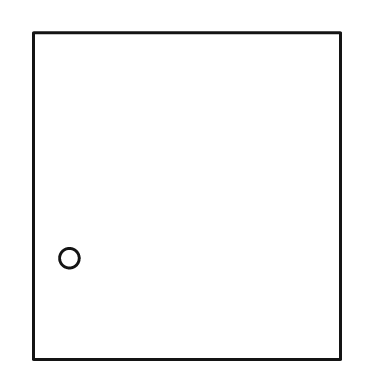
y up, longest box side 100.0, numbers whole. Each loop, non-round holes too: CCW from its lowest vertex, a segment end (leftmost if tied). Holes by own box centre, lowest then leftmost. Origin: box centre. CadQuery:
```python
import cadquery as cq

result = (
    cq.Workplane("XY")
    .moveTo(-47.0, -50.0)
    .lineTo(47.0, -50.0)
    .lineTo(47.0, 50.0)
    .lineTo(-47.0, 50.0)
    .close()
    .moveTo(-36.0, -19.0)
    .circle(3.0)
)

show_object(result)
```